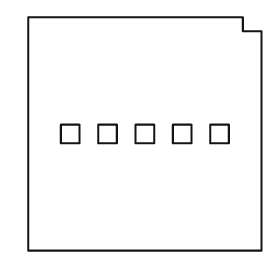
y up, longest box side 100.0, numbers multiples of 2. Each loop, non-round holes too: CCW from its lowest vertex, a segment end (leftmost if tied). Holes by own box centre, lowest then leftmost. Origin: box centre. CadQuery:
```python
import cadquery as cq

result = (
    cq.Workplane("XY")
    .moveTo(-50.0, -50.0)
    .lineTo(50.0, -50.0)
    .lineTo(50.0, 44.0)
    .lineTo(42.0, 44.0)
    .lineTo(42.0, 50.0)
    .lineTo(-50.0, 50.0)
    .close()
    .moveTo(-36.0, -4.0)
    .lineTo(-28.0, -4.0)
    .lineTo(-28.0, 4.0)
    .lineTo(-36.0, 4.0)
    .close()
    .moveTo(-20.0, -4.0)
    .lineTo(-12.0, -4.0)
    .lineTo(-12.0, 4.0)
    .lineTo(-20.0, 4.0)
    .close()
    .moveTo(-4.0, -4.0)
    .lineTo(4.0, -4.0)
    .lineTo(4.0, 4.0)
    .lineTo(-4.0, 4.0)
    .close()
    .moveTo(12.0, -4.0)
    .lineTo(20.0, -4.0)
    .lineTo(20.0, 4.0)
    .lineTo(12.0, 4.0)
    .close()
    .moveTo(28.0, -4.0)
    .lineTo(36.0, -4.0)
    .lineTo(36.0, 4.0)
    .lineTo(28.0, 4.0)
    .close()
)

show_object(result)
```